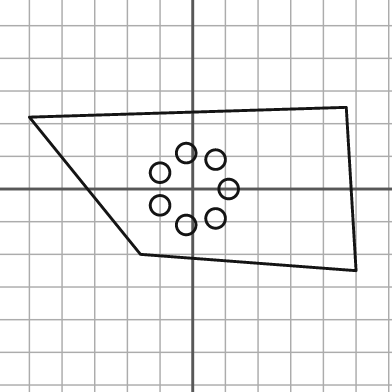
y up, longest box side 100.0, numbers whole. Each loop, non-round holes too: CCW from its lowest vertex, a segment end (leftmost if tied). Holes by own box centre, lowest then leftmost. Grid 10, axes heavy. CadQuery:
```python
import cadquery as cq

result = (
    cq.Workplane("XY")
    .moveTo(50.0, -25.0)
    .lineTo(47.0, 25.0)
    .lineTo(-50.0, 22.0)
    .lineTo(-16.0, -20.0)
    .close()
    .moveTo(-2.0, -11.0)
    .circle(3.0)
    .moveTo(7.0, -9.0)
    .circle(3.0)
    .moveTo(-10.0, -5.0)
    .circle(3.0)
    .moveTo(11.0, 0.0)
    .circle(3.0)
    .moveTo(-10.0, 5.0)
    .circle(3.0)
    .moveTo(7.0, 9.0)
    .circle(3.0)
    .moveTo(-2.0, 11.0)
    .circle(3.0)
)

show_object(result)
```